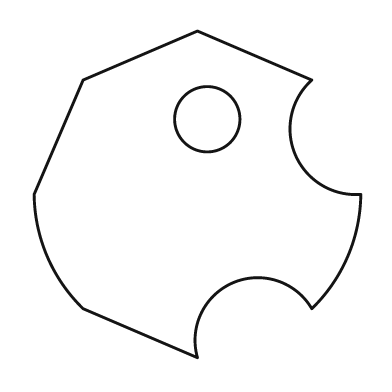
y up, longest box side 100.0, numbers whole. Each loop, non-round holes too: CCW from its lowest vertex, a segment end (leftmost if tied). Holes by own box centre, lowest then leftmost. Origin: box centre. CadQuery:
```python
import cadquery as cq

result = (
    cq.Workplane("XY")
    .moveTo(0.0, -50.0)
    .threePointArc((11.0, -27.0), (35.0, -35.0))
    .threePointArc((46.0, -19.0), (50.0, 0.0))
    .threePointArc((30.0, 12.0), (35.0, 35.0))
    .lineTo(0.0, 50.0)
    .lineTo(-35.0, 35.0)
    .lineTo(-50.0, 0.0)
    .threePointArc((-46.0, -19.0), (-35.0, -35.0))
    .close()
    .moveTo(3.0, 23.0)
    .circle(10.0)
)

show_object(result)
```